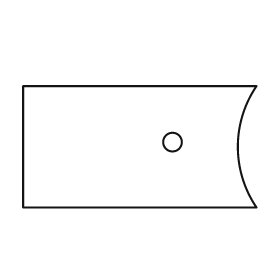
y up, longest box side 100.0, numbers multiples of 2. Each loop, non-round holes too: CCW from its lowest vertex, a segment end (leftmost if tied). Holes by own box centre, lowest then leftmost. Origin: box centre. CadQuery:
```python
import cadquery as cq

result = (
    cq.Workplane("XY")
    .moveTo(-50.0, -26.0)
    .lineTo(50.0, -26.0)
    .threePointArc((42.0, 0.0), (50.0, 26.0))
    .lineTo(-50.0, 26.0)
    .close()
    .moveTo(14.0, 2.0)
    .circle(4.0)
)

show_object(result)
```